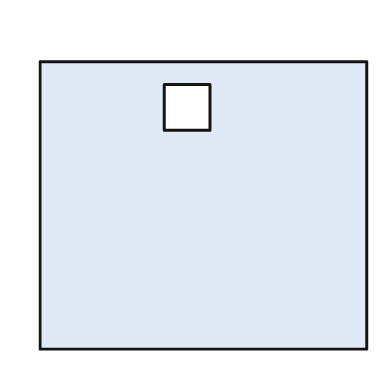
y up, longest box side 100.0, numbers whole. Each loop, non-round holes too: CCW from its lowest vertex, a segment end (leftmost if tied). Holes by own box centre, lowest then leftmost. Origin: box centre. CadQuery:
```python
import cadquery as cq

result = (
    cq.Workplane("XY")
    .moveTo(-50.0, -44.0)
    .lineTo(50.0, -44.0)
    .lineTo(50.0, 44.0)
    .lineTo(-50.0, 44.0)
    .close()
    .moveTo(-12.0, 23.0)
    .lineTo(2.0, 23.0)
    .lineTo(2.0, 37.0)
    .lineTo(-12.0, 37.0)
    .close()
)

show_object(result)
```